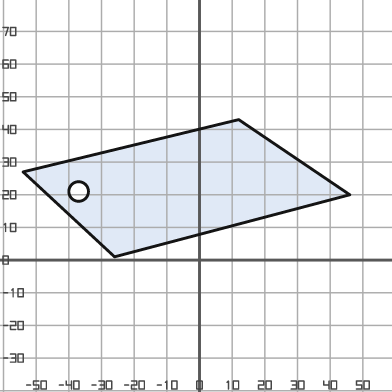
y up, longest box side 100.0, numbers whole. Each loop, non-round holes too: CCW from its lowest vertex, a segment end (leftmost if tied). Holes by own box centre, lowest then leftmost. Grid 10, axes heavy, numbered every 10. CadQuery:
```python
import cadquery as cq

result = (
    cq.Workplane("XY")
    .moveTo(-26.0, 1.0)
    .lineTo(46.0, 20.0)
    .lineTo(12.0, 43.0)
    .lineTo(-54.0, 27.0)
    .close()
    .moveTo(-37.0, 21.0)
    .circle(3.0)
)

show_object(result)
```